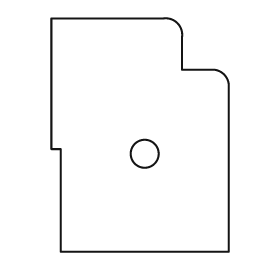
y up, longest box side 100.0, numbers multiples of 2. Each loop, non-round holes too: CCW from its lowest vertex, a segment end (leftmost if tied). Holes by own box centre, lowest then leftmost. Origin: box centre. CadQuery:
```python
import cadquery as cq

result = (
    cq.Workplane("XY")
    .moveTo(-34.0, -50.0)
    .lineTo(38.0, -50.0)
    .lineTo(38.0, 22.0)
    .threePointArc((36.0, 26.0), (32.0, 28.0))
    .lineTo(18.0, 28.0)
    .lineTo(18.0, 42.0)
    .threePointArc((16.0, 48.0), (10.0, 50.0))
    .lineTo(-38.0, 50.0)
    .lineTo(-38.0, -6.0)
    .lineTo(-34.0, -6.0)
    .close()
    .moveTo(2.0, -8.0)
    .circle(6.0)
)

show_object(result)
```